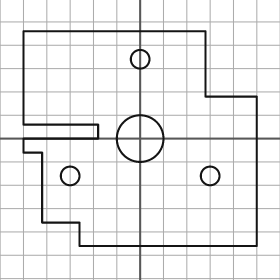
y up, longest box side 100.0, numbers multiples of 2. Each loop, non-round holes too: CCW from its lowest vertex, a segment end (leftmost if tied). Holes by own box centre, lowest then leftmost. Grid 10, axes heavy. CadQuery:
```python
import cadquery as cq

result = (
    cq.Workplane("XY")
    .moveTo(-26.0, -46.0)
    .lineTo(50.0, -46.0)
    .lineTo(50.0, 18.0)
    .lineTo(28.0, 18.0)
    .lineTo(28.0, 46.0)
    .lineTo(-50.0, 46.0)
    .lineTo(-50.0, 6.0)
    .lineTo(-18.0, 6.0)
    .lineTo(-18.0, 0.0)
    .lineTo(-50.0, 0.0)
    .lineTo(-50.0, -6.0)
    .lineTo(-42.0, -6.0)
    .lineTo(-42.0, -36.0)
    .lineTo(-26.0, -36.0)
    .close()
    .moveTo(-30.0, -16.0)
    .circle(4.0)
    .moveTo(30.0, -16.0)
    .circle(4.0)
    .moveTo(0.0, 0.0)
    .circle(10.0)
    .moveTo(0.0, 34.0)
    .circle(4.0)
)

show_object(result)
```